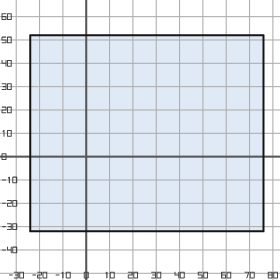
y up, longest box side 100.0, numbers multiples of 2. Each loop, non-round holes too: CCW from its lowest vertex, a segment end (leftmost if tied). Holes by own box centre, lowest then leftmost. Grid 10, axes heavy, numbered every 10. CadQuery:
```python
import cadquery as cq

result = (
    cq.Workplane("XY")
    .moveTo(-24.0, -32.0)
    .lineTo(76.0, -32.0)
    .lineTo(76.0, 52.0)
    .lineTo(-24.0, 52.0)
    .close()
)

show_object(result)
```